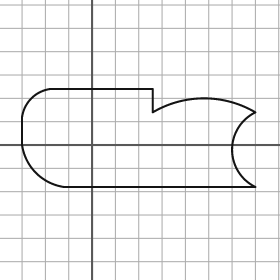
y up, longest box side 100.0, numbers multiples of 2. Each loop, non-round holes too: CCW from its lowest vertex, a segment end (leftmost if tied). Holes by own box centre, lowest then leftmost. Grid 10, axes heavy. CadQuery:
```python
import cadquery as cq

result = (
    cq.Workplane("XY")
    .moveTo(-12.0, -18.0)
    .lineTo(70.0, -18.0)
    .threePointArc((60.0, -2.0), (70.0, 14.0))
    .threePointArc((48.0, 20.0), (26.0, 14.0))
    .lineTo(26.0, 24.0)
    .lineTo(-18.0, 24.0)
    .threePointArc((-26.0, 20.0), (-30.0, 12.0))
    .lineTo(-30.0, 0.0)
    .threePointArc((-24.0, -12.0), (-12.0, -18.0))
    .close()
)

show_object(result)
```